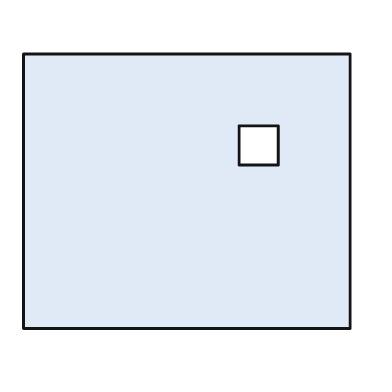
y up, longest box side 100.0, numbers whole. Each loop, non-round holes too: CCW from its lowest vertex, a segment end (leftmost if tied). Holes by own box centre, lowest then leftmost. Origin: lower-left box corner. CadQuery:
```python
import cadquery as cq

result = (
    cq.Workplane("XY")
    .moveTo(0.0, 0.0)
    .lineTo(100.0, 0.0)
    .lineTo(100.0, 84.0)
    .lineTo(0.0, 84.0)
    .close()
    .moveTo(66.0, 50.0)
    .lineTo(78.0, 50.0)
    .lineTo(78.0, 62.0)
    .lineTo(66.0, 62.0)
    .close()
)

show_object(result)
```